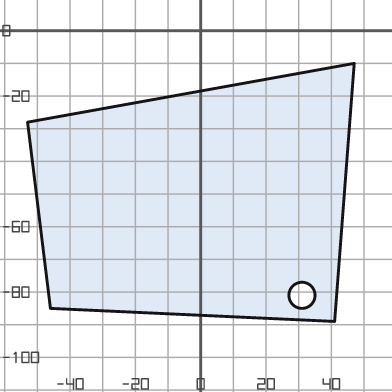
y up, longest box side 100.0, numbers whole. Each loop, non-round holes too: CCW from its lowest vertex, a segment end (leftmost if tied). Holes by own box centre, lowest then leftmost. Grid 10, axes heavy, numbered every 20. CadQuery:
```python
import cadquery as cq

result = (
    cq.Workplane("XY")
    .moveTo(41.0, -89.0)
    .lineTo(47.0, -10.0)
    .lineTo(-53.0, -28.0)
    .lineTo(-46.0, -85.0)
    .close()
    .moveTo(31.0, -81.0)
    .circle(4.0)
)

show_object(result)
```